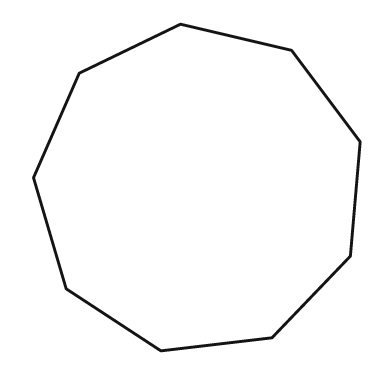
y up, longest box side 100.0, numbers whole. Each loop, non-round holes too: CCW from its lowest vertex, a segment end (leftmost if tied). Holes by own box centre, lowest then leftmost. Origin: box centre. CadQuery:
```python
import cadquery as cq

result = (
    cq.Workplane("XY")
    .moveTo(-11.0, -50.0)
    .lineTo(23.0, -46.0)
    .lineTo(47.0, -21.0)
    .lineTo(50.0, 14.0)
    .lineTo(29.0, 42.0)
    .lineTo(-5.0, 50.0)
    .lineTo(-36.0, 35.0)
    .lineTo(-50.0, 3.0)
    .lineTo(-40.0, -31.0)
    .close()
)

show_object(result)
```